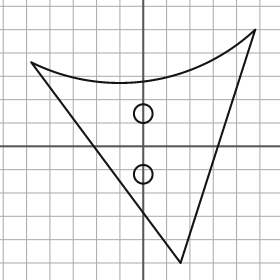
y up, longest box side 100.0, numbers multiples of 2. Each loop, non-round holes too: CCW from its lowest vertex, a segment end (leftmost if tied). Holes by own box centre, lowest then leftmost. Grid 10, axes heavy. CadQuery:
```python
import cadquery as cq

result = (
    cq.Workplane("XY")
    .moveTo(16.0, -50.0)
    .lineTo(48.0, 50.0)
    .threePointArc((2.0, 28.0), (-48.0, 36.0))
    .close()
    .moveTo(0.0, -12.0)
    .circle(4.0)
    .moveTo(0.0, 14.0)
    .circle(4.0)
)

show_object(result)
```